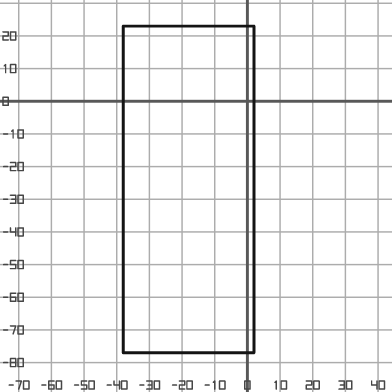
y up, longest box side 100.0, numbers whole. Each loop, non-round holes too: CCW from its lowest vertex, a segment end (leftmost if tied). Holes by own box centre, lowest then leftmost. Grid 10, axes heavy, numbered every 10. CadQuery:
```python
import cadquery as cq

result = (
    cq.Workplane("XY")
    .moveTo(-38.0, -77.0)
    .lineTo(2.0, -77.0)
    .lineTo(2.0, 23.0)
    .lineTo(-38.0, 23.0)
    .close()
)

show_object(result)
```